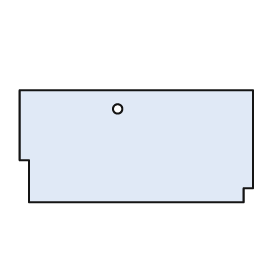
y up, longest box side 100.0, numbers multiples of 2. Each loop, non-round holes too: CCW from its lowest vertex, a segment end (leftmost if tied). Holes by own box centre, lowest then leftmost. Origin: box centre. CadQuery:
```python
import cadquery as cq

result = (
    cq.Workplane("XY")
    .moveTo(-46.0, -24.0)
    .lineTo(46.0, -24.0)
    .lineTo(46.0, -18.0)
    .lineTo(50.0, -18.0)
    .lineTo(50.0, 24.0)
    .lineTo(-50.0, 24.0)
    .lineTo(-50.0, -6.0)
    .lineTo(-46.0, -6.0)
    .close()
    .moveTo(-8.0, 16.0)
    .circle(2.0)
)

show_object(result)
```